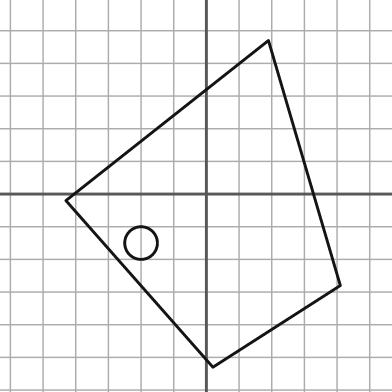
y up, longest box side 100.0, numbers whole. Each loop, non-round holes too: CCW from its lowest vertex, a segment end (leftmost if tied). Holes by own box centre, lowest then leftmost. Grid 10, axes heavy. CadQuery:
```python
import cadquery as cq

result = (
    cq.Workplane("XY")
    .moveTo(2.0, -53.0)
    .lineTo(41.0, -28.0)
    .lineTo(19.0, 47.0)
    .lineTo(-43.0, -2.0)
    .close()
    .moveTo(-20.0, -15.0)
    .circle(5.0)
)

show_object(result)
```